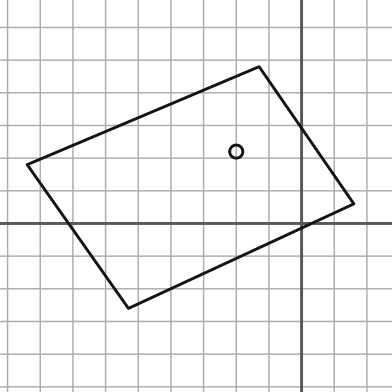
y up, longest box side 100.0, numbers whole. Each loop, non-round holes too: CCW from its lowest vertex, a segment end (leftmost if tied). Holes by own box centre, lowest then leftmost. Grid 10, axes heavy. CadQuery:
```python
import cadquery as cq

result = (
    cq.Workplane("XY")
    .moveTo(-53.0, -26.0)
    .lineTo(16.0, 6.0)
    .lineTo(-13.0, 48.0)
    .lineTo(-84.0, 18.0)
    .close()
    .moveTo(-20.0, 22.0)
    .circle(2.0)
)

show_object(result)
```